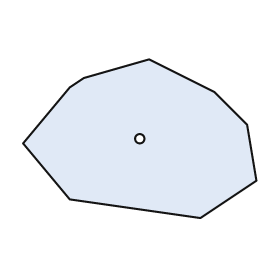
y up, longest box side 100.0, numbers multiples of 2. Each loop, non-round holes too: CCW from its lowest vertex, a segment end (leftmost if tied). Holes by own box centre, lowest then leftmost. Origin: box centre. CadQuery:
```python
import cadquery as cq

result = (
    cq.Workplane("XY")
    .moveTo(26.0, -34.0)
    .lineTo(50.0, -18.0)
    .lineTo(46.0, 6.0)
    .lineTo(32.0, 20.0)
    .lineTo(4.0, 34.0)
    .lineTo(-24.0, 26.0)
    .lineTo(-30.0, 22.0)
    .lineTo(-50.0, -2.0)
    .lineTo(-30.0, -26.0)
    .close()
    .moveTo(0.0, 0.0)
    .circle(2.0)
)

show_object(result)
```